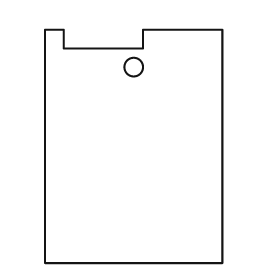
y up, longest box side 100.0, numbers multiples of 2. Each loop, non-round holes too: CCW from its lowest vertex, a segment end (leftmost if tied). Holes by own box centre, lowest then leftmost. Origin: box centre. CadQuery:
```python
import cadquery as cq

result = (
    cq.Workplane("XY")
    .moveTo(-38.0, -50.0)
    .lineTo(38.0, -50.0)
    .lineTo(38.0, 50.0)
    .lineTo(4.0, 50.0)
    .lineTo(4.0, 42.0)
    .lineTo(-30.0, 42.0)
    .lineTo(-30.0, 50.0)
    .lineTo(-38.0, 50.0)
    .close()
    .moveTo(0.0, 34.0)
    .circle(4.0)
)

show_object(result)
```